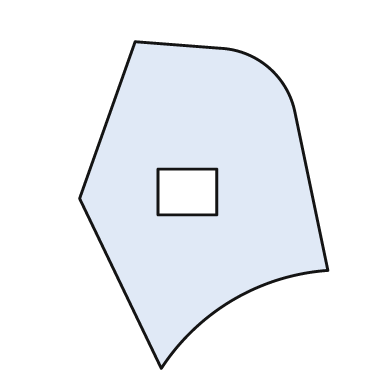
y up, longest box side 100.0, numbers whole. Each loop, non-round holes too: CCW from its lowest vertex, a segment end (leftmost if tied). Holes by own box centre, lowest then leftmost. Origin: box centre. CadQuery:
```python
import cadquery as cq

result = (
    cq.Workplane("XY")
    .moveTo(-13.0, -50.0)
    .threePointArc((9.0, -29.0), (38.0, -20.0))
    .lineTo(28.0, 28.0)
    .threePointArc((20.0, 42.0), (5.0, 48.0))
    .lineTo(-21.0, 50.0)
    .lineTo(-38.0, 2.0)
    .close()
    .moveTo(-14.0, -3.0)
    .lineTo(4.0, -3.0)
    .lineTo(4.0, 11.0)
    .lineTo(-14.0, 11.0)
    .close()
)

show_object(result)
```